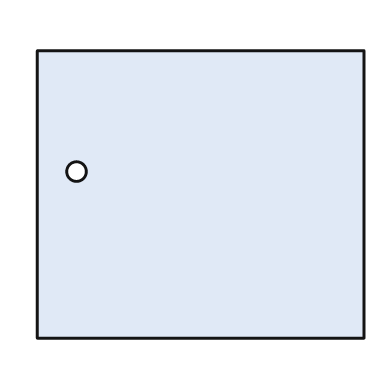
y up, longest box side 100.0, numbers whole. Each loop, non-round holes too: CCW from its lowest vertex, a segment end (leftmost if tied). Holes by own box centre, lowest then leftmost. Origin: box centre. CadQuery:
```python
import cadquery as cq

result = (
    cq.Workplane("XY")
    .moveTo(-50.0, -44.0)
    .lineTo(50.0, -44.0)
    .lineTo(50.0, 44.0)
    .lineTo(-50.0, 44.0)
    .close()
    .moveTo(-38.0, 7.0)
    .circle(3.0)
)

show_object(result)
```